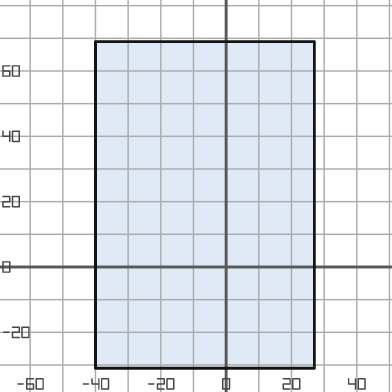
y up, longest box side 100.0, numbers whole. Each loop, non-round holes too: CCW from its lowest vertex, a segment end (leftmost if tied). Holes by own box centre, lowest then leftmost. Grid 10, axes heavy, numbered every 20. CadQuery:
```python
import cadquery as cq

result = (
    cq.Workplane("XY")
    .moveTo(-40.0, -31.0)
    .lineTo(27.0, -31.0)
    .lineTo(27.0, 69.0)
    .lineTo(-40.0, 69.0)
    .close()
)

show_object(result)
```